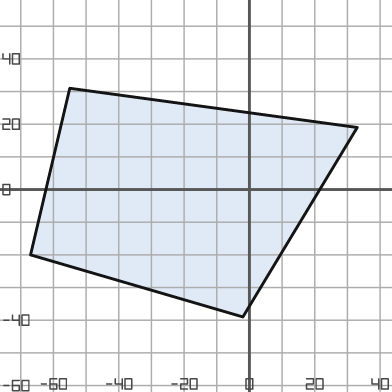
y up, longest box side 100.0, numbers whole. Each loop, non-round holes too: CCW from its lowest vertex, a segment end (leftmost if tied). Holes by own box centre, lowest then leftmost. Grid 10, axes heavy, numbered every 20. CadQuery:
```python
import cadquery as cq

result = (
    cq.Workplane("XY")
    .moveTo(-2.0, -39.0)
    .lineTo(33.0, 19.0)
    .lineTo(-55.0, 31.0)
    .lineTo(-67.0, -20.0)
    .close()
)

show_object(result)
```